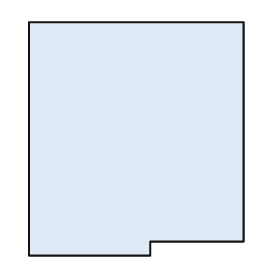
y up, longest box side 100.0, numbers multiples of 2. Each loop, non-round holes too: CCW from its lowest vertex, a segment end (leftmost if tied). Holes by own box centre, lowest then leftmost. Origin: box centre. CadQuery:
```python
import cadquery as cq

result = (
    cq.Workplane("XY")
    .moveTo(-46.0, -50.0)
    .lineTo(6.0, -50.0)
    .lineTo(6.0, -44.0)
    .lineTo(46.0, -44.0)
    .lineTo(46.0, 50.0)
    .lineTo(-46.0, 50.0)
    .close()
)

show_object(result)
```